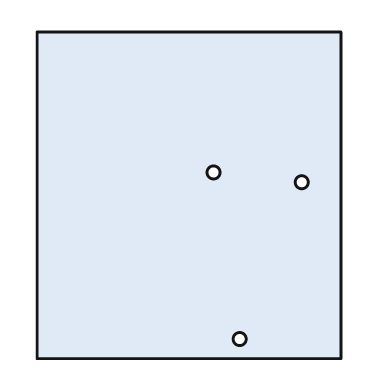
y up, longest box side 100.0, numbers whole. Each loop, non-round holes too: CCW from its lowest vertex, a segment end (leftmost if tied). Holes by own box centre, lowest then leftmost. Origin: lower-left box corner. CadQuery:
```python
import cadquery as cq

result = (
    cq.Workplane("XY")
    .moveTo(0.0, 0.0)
    .lineTo(93.0, 0.0)
    .lineTo(93.0, 100.0)
    .lineTo(0.0, 100.0)
    .close()
    .moveTo(62.0, 6.0)
    .circle(2.0)
    .moveTo(81.0, 54.0)
    .circle(2.0)
    .moveTo(54.0, 57.0)
    .circle(2.0)
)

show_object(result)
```